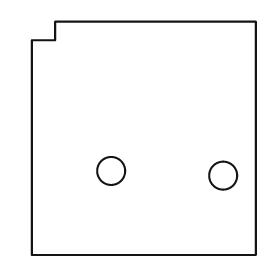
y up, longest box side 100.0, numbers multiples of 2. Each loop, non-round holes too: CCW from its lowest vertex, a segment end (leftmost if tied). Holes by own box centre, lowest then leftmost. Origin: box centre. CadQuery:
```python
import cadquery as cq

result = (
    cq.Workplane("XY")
    .moveTo(-48.0, -50.0)
    .lineTo(48.0, -50.0)
    .lineTo(48.0, 50.0)
    .lineTo(-38.0, 50.0)
    .lineTo(-38.0, 42.0)
    .lineTo(-48.0, 42.0)
    .close()
    .moveTo(34.0, -16.0)
    .circle(6.0)
    .moveTo(-14.0, -14.0)
    .circle(6.0)
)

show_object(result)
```